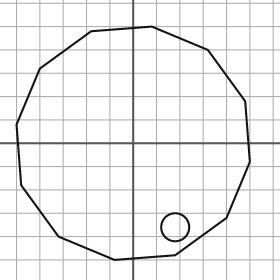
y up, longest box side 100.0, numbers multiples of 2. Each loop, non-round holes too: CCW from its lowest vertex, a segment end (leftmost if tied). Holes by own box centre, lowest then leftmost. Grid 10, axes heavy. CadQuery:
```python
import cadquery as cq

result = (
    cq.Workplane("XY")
    .moveTo(-8.0, -50.0)
    .lineTo(18.0, -48.0)
    .lineTo(40.0, -32.0)
    .lineTo(50.0, -8.0)
    .lineTo(48.0, 18.0)
    .lineTo(32.0, 40.0)
    .lineTo(8.0, 50.0)
    .lineTo(-18.0, 48.0)
    .lineTo(-40.0, 32.0)
    .lineTo(-50.0, 8.0)
    .lineTo(-48.0, -18.0)
    .lineTo(-32.0, -40.0)
    .close()
    .moveTo(18.0, -36.0)
    .circle(6.0)
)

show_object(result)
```